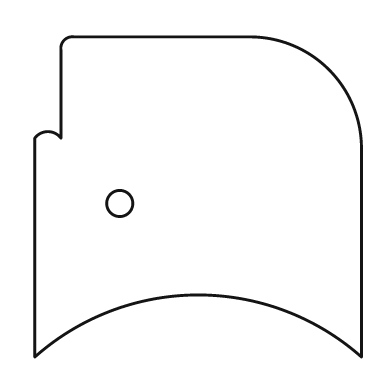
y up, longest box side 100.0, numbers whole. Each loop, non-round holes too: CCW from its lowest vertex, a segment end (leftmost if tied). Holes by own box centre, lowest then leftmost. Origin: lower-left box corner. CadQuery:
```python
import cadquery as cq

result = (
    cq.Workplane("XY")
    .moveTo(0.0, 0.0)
    .threePointArc((50.0, 19.0), (100.0, 0.0))
    .lineTo(100.0, 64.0)
    .threePointArc((90.0, 88.0), (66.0, 98.0))
    .lineTo(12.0, 98.0)
    .threePointArc((9.0, 97.0), (8.0, 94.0))
    .lineTo(8.0, 67.0)
    .threePointArc((4.0, 69.0), (0.0, 67.0))
    .close()
    .moveTo(26.0, 47.0)
    .circle(4.0)
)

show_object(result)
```